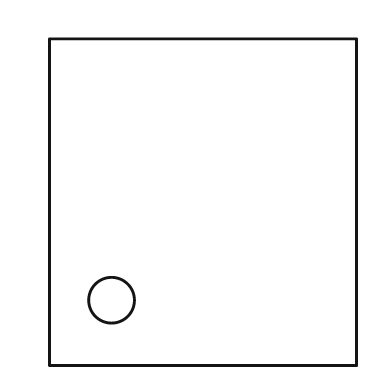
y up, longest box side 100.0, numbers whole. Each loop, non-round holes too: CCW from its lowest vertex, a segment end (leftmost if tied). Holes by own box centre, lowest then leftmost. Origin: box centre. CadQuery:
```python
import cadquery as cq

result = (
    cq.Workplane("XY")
    .moveTo(-47.0, -50.0)
    .lineTo(47.0, -50.0)
    .lineTo(47.0, 50.0)
    .lineTo(-47.0, 50.0)
    .close()
    .moveTo(-28.0, -30.0)
    .circle(7.0)
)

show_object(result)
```